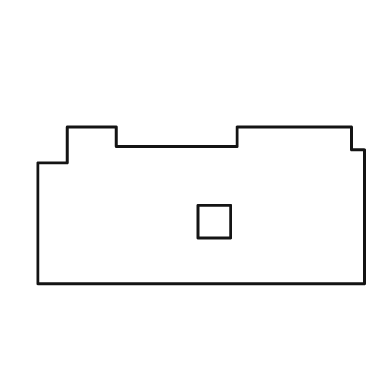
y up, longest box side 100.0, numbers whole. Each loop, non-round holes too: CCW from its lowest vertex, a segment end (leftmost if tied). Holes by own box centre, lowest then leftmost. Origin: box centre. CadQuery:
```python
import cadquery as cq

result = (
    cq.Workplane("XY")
    .moveTo(-50.0, -24.0)
    .lineTo(50.0, -24.0)
    .lineTo(50.0, 17.0)
    .lineTo(46.0, 17.0)
    .lineTo(46.0, 24.0)
    .lineTo(11.0, 24.0)
    .lineTo(11.0, 18.0)
    .lineTo(-26.0, 18.0)
    .lineTo(-26.0, 24.0)
    .lineTo(-41.0, 24.0)
    .lineTo(-41.0, 13.0)
    .lineTo(-50.0, 13.0)
    .close()
    .moveTo(-1.0, -10.0)
    .lineTo(9.0, -10.0)
    .lineTo(9.0, 0.0)
    .lineTo(-1.0, 0.0)
    .close()
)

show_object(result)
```